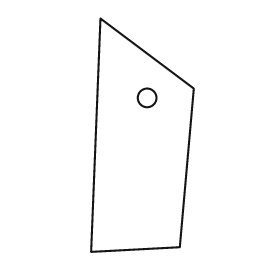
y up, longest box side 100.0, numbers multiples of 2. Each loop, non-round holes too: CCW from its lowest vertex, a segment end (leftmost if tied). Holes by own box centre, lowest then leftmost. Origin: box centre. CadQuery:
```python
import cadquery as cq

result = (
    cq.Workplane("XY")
    .moveTo(-22.0, -50.0)
    .lineTo(16.0, -48.0)
    .lineTo(22.0, 20.0)
    .lineTo(-18.0, 50.0)
    .close()
    .moveTo(2.0, 16.0)
    .circle(4.0)
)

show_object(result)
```